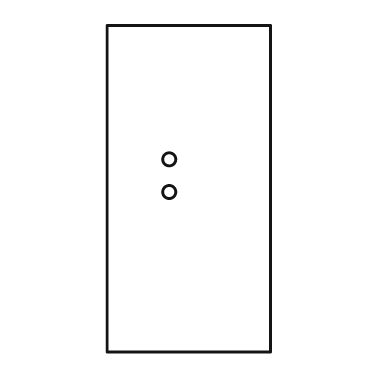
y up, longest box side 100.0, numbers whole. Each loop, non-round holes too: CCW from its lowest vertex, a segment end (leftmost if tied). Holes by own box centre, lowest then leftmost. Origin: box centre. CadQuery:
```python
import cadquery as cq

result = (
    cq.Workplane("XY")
    .moveTo(-25.0, -50.0)
    .lineTo(25.0, -50.0)
    .lineTo(25.0, 50.0)
    .lineTo(-25.0, 50.0)
    .close()
    .moveTo(-6.0, -1.0)
    .circle(2.0)
    .moveTo(-6.0, 9.0)
    .circle(2.0)
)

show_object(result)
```